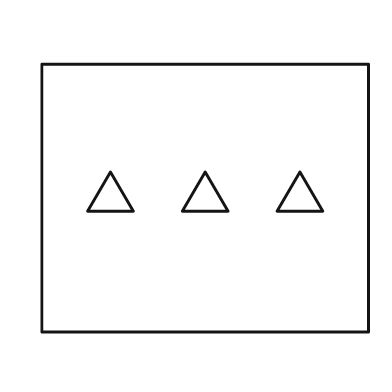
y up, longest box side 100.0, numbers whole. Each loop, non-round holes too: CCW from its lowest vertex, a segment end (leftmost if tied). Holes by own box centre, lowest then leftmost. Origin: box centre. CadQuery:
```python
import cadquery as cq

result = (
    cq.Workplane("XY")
    .moveTo(-50.0, -41.0)
    .lineTo(50.0, -41.0)
    .lineTo(50.0, 41.0)
    .lineTo(-50.0, 41.0)
    .close()
    .moveTo(-36.0, -4.0)
    .lineTo(-22.0, -4.0)
    .lineTo(-29.0, 8.0)
    .close()
    .moveTo(-7.0, -4.0)
    .lineTo(7.0, -4.0)
    .lineTo(0.0, 8.0)
    .close()
    .moveTo(22.0, -4.0)
    .lineTo(36.0, -4.0)
    .lineTo(29.0, 8.0)
    .close()
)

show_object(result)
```